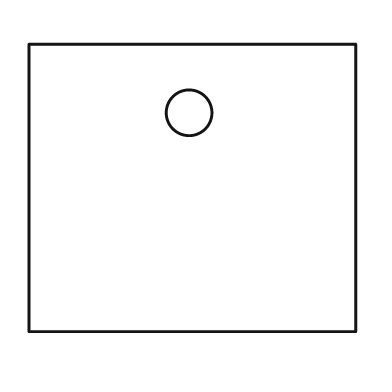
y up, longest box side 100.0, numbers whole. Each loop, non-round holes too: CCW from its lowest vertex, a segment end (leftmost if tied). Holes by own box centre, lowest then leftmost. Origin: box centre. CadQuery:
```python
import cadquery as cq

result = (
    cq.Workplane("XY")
    .moveTo(-50.0, -44.0)
    .lineTo(50.0, -44.0)
    .lineTo(50.0, 44.0)
    .lineTo(-50.0, 44.0)
    .close()
    .moveTo(-1.0, 23.0)
    .circle(7.0)
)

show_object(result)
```